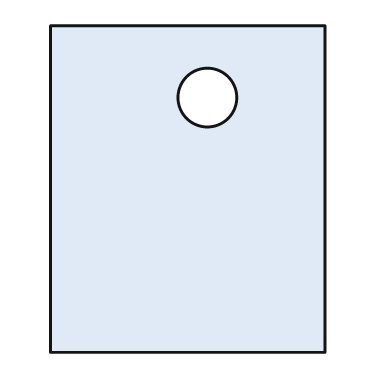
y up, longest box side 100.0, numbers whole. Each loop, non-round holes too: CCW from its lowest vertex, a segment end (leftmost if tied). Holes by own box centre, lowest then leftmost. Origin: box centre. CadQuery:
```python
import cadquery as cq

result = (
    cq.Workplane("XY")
    .moveTo(-42.0, -50.0)
    .lineTo(42.0, -50.0)
    .lineTo(42.0, 50.0)
    .lineTo(-42.0, 50.0)
    .close()
    .moveTo(6.0, 28.0)
    .circle(9.0)
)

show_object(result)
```